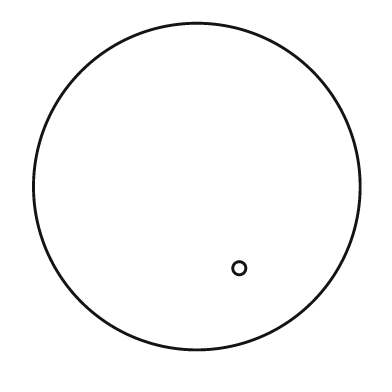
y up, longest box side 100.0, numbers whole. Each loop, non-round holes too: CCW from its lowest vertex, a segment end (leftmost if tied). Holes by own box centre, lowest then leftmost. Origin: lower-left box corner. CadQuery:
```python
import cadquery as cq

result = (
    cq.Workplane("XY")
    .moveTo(50.0, 50.0)
    .circle(50.0)
    .moveTo(63.0, 25.0)
    .circle(2.0)
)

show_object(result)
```